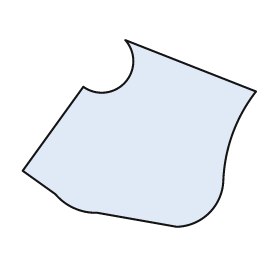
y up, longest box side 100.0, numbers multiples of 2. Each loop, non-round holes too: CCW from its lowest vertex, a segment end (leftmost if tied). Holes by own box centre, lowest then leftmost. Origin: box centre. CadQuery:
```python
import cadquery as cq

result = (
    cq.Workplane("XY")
    .moveTo(16.0, -40.0)
    .threePointArc((30.0, -34.0), (36.0, -20.0))
    .threePointArc((40.0, 0.0), (50.0, 18.0))
    .lineTo(-6.0, 40.0)
    .threePointArc((-6.0, 22.0), (-24.0, 20.0))
    .lineTo(-50.0, -16.0)
    .lineTo(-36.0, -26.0)
    .threePointArc((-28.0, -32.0), (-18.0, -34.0))
    .close()
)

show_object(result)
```